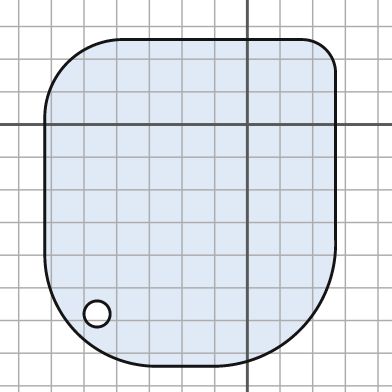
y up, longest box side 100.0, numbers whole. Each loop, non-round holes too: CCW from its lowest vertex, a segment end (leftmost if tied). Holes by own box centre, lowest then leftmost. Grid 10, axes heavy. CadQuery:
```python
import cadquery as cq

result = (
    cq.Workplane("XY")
    .moveTo(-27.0, -74.0)
    .lineTo(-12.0, -74.0)
    .threePointArc((16.0, -63.0), (27.0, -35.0))
    .lineTo(27.0, 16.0)
    .threePointArc((24.0, 23.0), (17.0, 26.0))
    .lineTo(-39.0, 26.0)
    .threePointArc((-55.0, 19.0), (-62.0, 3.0))
    .lineTo(-62.0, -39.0)
    .threePointArc((-52.0, -64.0), (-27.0, -74.0))
    .close()
    .moveTo(-46.0, -58.0)
    .circle(4.0)
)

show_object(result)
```